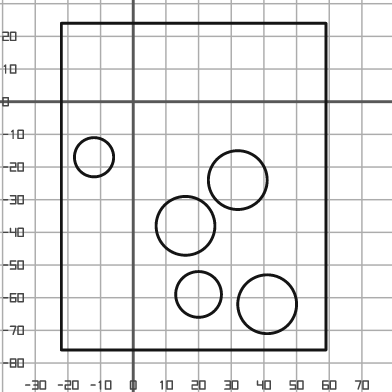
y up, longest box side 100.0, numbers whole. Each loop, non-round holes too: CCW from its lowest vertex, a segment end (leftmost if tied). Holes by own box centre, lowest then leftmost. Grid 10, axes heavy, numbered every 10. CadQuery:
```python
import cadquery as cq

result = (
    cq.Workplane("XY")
    .moveTo(-22.0, -76.0)
    .lineTo(59.0, -76.0)
    .lineTo(59.0, 24.0)
    .lineTo(-22.0, 24.0)
    .close()
    .moveTo(41.0, -62.0)
    .circle(9.0)
    .moveTo(20.0, -59.0)
    .circle(7.0)
    .moveTo(16.0, -38.0)
    .circle(9.0)
    .moveTo(32.0, -24.0)
    .circle(9.0)
    .moveTo(-12.0, -17.0)
    .circle(6.0)
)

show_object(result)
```